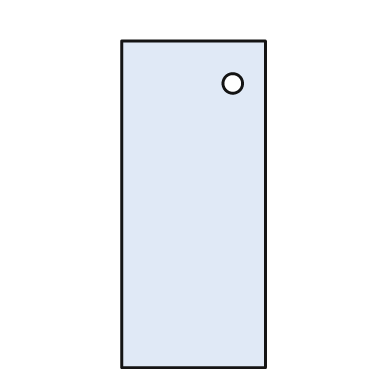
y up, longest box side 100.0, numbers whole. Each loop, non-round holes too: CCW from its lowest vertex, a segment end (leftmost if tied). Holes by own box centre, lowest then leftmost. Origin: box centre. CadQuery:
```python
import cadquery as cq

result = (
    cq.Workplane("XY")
    .moveTo(-22.0, -50.0)
    .lineTo(22.0, -50.0)
    .lineTo(22.0, 50.0)
    .lineTo(-22.0, 50.0)
    .close()
    .moveTo(12.0, 37.0)
    .circle(3.0)
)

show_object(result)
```